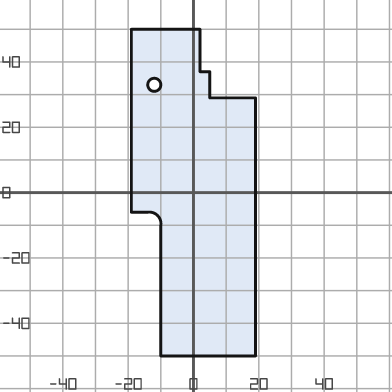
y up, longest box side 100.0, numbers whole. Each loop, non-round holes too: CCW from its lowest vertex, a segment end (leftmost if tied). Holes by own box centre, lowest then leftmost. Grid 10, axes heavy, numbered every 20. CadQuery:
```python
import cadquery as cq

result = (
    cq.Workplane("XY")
    .moveTo(-10.0, -50.0)
    .lineTo(19.0, -50.0)
    .lineTo(19.0, 29.0)
    .lineTo(5.0, 29.0)
    .lineTo(5.0, 37.0)
    .lineTo(2.0, 37.0)
    .lineTo(2.0, 50.0)
    .lineTo(-19.0, 50.0)
    .lineTo(-19.0, -6.0)
    .lineTo(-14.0, -6.0)
    .threePointArc((-11.0, -7.0), (-10.0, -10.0))
    .close()
    .moveTo(-12.0, 33.0)
    .circle(2.0)
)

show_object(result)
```